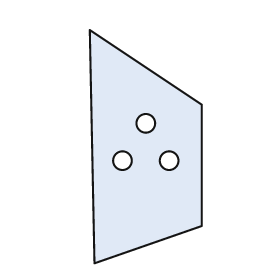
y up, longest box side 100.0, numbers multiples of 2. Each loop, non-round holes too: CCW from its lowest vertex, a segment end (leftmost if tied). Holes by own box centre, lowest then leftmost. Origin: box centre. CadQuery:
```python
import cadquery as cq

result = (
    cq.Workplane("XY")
    .moveTo(-22.0, -50.0)
    .lineTo(24.0, -34.0)
    .lineTo(24.0, 18.0)
    .lineTo(-24.0, 50.0)
    .close()
    .moveTo(-10.0, -6.0)
    .circle(4.0)
    .moveTo(10.0, -6.0)
    .circle(4.0)
    .moveTo(0.0, 10.0)
    .circle(4.0)
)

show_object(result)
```